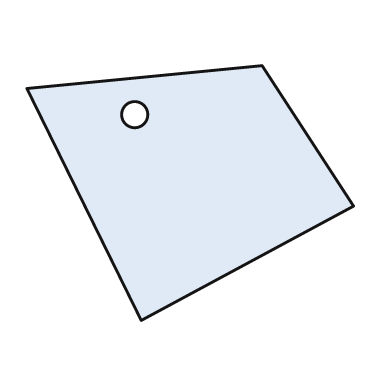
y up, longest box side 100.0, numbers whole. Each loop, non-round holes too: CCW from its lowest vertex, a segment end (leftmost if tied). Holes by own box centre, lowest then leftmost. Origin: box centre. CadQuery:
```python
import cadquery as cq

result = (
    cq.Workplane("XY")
    .moveTo(-15.0, -39.0)
    .lineTo(50.0, -4.0)
    .lineTo(22.0, 39.0)
    .lineTo(-50.0, 32.0)
    .close()
    .moveTo(-17.0, 24.0)
    .circle(4.0)
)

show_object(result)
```